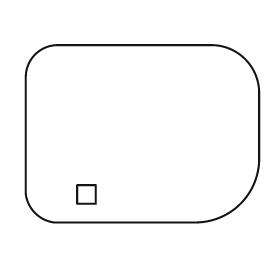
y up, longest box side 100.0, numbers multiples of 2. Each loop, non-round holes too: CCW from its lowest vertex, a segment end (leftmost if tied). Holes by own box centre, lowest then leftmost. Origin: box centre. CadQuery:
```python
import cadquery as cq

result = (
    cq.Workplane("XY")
    .moveTo(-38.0, -38.0)
    .lineTo(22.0, -38.0)
    .threePointArc((42.0, -30.0), (50.0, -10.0))
    .lineTo(50.0, 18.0)
    .threePointArc((44.0, 32.0), (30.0, 38.0))
    .lineTo(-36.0, 38.0)
    .threePointArc((-46.0, 34.0), (-50.0, 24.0))
    .lineTo(-50.0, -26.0)
    .threePointArc((-46.0, -34.0), (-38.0, -38.0))
    .close()
    .moveTo(-28.0, -30.0)
    .lineTo(-20.0, -30.0)
    .lineTo(-20.0, -22.0)
    .lineTo(-28.0, -22.0)
    .close()
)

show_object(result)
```